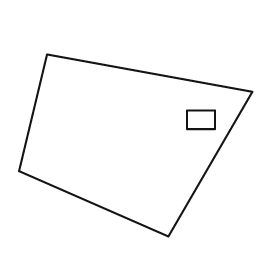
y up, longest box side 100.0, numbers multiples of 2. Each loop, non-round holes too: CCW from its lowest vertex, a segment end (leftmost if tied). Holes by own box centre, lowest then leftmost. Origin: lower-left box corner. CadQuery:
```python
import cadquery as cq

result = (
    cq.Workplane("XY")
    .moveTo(64.0, 0.0)
    .lineTo(100.0, 62.0)
    .lineTo(12.0, 78.0)
    .lineTo(0.0, 28.0)
    .close()
    .moveTo(72.0, 46.0)
    .lineTo(84.0, 46.0)
    .lineTo(84.0, 54.0)
    .lineTo(72.0, 54.0)
    .close()
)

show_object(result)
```